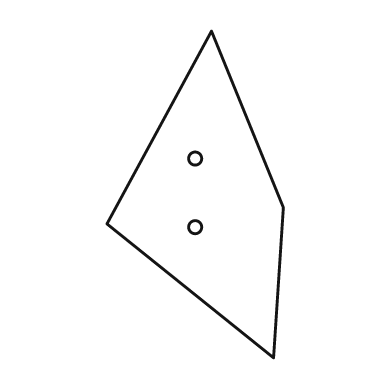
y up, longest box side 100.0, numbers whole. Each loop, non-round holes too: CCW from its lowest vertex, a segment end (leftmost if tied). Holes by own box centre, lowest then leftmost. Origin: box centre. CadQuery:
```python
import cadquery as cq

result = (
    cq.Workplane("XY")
    .moveTo(24.0, -50.0)
    .lineTo(27.0, -4.0)
    .lineTo(5.0, 50.0)
    .lineTo(-27.0, -9.0)
    .close()
    .moveTo(0.0, -10.0)
    .circle(2.0)
    .moveTo(0.0, 11.0)
    .circle(2.0)
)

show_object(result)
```